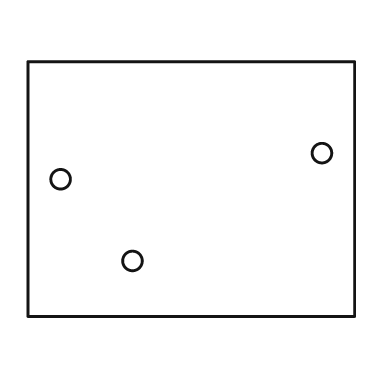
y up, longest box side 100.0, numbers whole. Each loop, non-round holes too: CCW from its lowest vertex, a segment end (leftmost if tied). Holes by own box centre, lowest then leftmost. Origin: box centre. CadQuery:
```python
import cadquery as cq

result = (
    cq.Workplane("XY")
    .moveTo(-50.0, -39.0)
    .lineTo(50.0, -39.0)
    .lineTo(50.0, 39.0)
    .lineTo(-50.0, 39.0)
    .close()
    .moveTo(-18.0, -22.0)
    .circle(3.0)
    .moveTo(-40.0, 3.0)
    .circle(3.0)
    .moveTo(40.0, 11.0)
    .circle(3.0)
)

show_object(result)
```